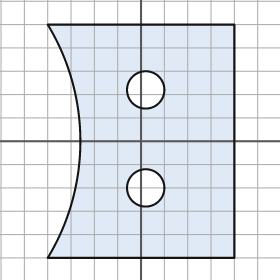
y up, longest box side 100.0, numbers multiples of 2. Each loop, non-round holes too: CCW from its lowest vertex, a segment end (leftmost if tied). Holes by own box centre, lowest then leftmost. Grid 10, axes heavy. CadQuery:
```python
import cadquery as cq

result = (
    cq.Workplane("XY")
    .moveTo(-40.0, -50.0)
    .lineTo(40.0, -50.0)
    .lineTo(40.0, 50.0)
    .lineTo(-40.0, 50.0)
    .threePointArc((-26.0, 0.0), (-40.0, -50.0))
    .close()
    .moveTo(2.0, -20.0)
    .circle(8.0)
    .moveTo(2.0, 22.0)
    .circle(8.0)
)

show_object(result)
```